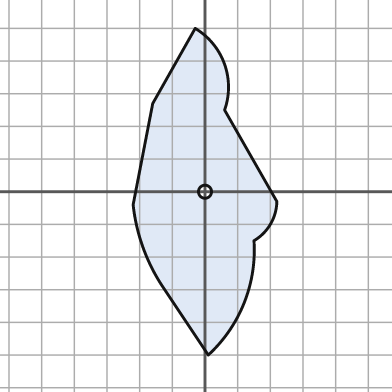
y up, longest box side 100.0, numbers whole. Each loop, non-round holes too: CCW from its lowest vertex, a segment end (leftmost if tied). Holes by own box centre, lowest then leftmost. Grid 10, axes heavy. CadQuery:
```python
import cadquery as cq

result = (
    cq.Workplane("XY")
    .moveTo(1.0, -50.0)
    .threePointArc((12.0, -34.0), (15.0, -15.0))
    .threePointArc((20.0, -10.0), (22.0, -3.0))
    .lineTo(6.0, 25.0)
    .threePointArc((6.0, 39.0), (-3.0, 50.0))
    .lineTo(-16.0, 27.0)
    .lineTo(-22.0, -4.0)
    .threePointArc((-19.0, -17.0), (-13.0, -29.0))
    .close()
    .moveTo(0.0, 0.0)
    .circle(2.0)
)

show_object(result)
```